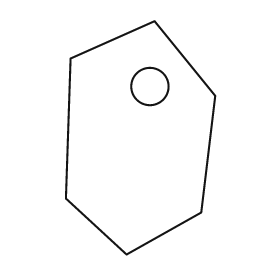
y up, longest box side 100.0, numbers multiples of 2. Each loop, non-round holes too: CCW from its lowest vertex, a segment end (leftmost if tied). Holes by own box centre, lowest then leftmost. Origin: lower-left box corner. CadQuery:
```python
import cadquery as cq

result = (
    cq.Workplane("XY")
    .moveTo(26.0, 0.0)
    .lineTo(58.0, 18.0)
    .lineTo(64.0, 68.0)
    .lineTo(38.0, 100.0)
    .lineTo(2.0, 84.0)
    .lineTo(0.0, 24.0)
    .close()
    .moveTo(36.0, 72.0)
    .circle(8.0)
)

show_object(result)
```